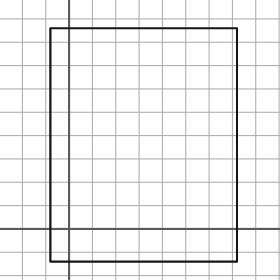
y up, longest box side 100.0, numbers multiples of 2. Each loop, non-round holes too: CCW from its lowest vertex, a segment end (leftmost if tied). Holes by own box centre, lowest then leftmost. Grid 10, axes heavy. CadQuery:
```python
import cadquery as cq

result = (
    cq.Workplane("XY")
    .moveTo(-8.0, -14.0)
    .lineTo(72.0, -14.0)
    .lineTo(72.0, 86.0)
    .lineTo(-8.0, 86.0)
    .close()
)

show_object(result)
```